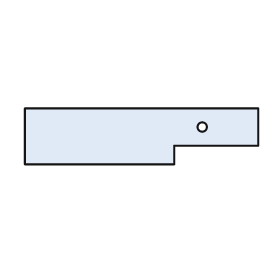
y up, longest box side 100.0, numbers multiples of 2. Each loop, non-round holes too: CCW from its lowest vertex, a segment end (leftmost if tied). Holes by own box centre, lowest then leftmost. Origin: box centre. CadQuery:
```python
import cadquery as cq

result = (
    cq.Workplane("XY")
    .moveTo(-50.0, -12.0)
    .lineTo(14.0, -12.0)
    .lineTo(14.0, -4.0)
    .lineTo(50.0, -4.0)
    .lineTo(50.0, 12.0)
    .lineTo(-50.0, 12.0)
    .close()
    .moveTo(26.0, 4.0)
    .circle(2.0)
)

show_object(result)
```